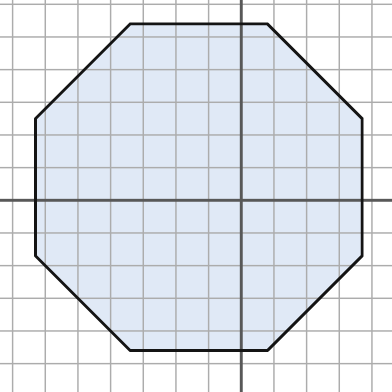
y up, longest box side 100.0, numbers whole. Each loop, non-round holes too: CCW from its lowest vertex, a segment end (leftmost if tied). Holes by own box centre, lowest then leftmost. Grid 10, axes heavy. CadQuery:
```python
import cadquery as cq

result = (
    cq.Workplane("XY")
    .moveTo(-34.0, -46.0)
    .lineTo(8.0, -46.0)
    .lineTo(37.0, -17.0)
    .lineTo(37.0, 25.0)
    .lineTo(8.0, 54.0)
    .lineTo(-34.0, 54.0)
    .lineTo(-63.0, 25.0)
    .lineTo(-63.0, -17.0)
    .close()
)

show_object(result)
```